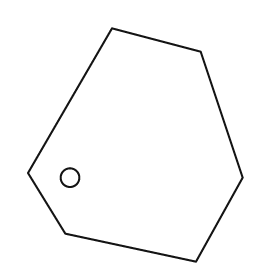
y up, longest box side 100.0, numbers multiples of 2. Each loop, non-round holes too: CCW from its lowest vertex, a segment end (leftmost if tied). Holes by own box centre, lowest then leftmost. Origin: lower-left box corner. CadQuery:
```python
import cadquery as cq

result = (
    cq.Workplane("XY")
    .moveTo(72.0, 0.0)
    .lineTo(92.0, 36.0)
    .lineTo(74.0, 90.0)
    .lineTo(36.0, 100.0)
    .lineTo(0.0, 38.0)
    .lineTo(16.0, 12.0)
    .close()
    .moveTo(18.0, 36.0)
    .circle(4.0)
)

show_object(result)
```